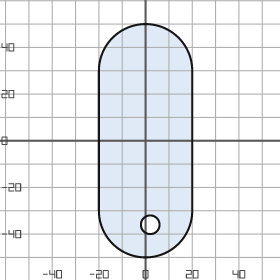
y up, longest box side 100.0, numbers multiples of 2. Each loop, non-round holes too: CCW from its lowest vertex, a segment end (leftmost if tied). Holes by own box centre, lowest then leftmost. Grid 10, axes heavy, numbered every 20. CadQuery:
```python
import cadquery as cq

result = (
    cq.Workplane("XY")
    .moveTo(-20.0, -30.0)
    .threePointArc((0.0, -50.0), (20.0, -30.0))
    .lineTo(20.0, 30.0)
    .threePointArc((0.0, 50.0), (-20.0, 30.0))
    .close()
    .moveTo(2.0, -36.0)
    .circle(4.0)
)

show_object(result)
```